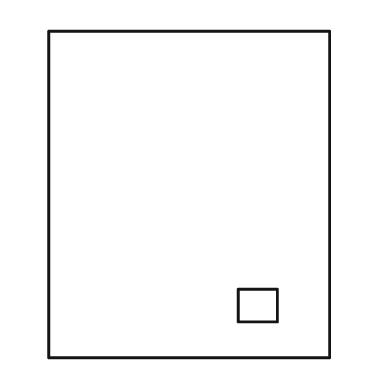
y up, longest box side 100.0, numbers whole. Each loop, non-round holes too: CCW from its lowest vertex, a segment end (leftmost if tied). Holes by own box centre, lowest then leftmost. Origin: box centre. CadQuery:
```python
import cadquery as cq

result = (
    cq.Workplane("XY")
    .moveTo(-43.0, -50.0)
    .lineTo(43.0, -50.0)
    .lineTo(43.0, 50.0)
    .lineTo(-43.0, 50.0)
    .close()
    .moveTo(15.0, -39.0)
    .lineTo(27.0, -39.0)
    .lineTo(27.0, -29.0)
    .lineTo(15.0, -29.0)
    .close()
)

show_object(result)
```